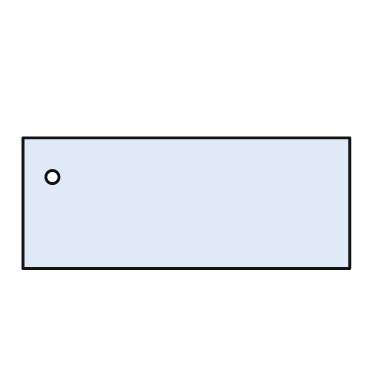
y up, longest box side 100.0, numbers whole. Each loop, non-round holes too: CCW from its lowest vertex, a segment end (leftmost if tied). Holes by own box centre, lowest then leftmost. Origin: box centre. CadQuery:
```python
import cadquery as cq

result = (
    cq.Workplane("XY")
    .moveTo(-50.0, -20.0)
    .lineTo(50.0, -20.0)
    .lineTo(50.0, 20.0)
    .lineTo(-50.0, 20.0)
    .close()
    .moveTo(-41.0, 8.0)
    .circle(2.0)
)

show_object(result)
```